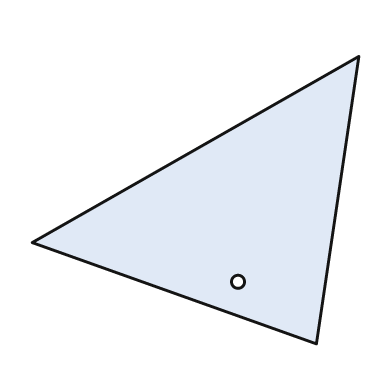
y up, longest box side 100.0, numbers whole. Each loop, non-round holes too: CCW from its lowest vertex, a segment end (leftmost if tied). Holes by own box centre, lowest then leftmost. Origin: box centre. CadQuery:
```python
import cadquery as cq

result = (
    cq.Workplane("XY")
    .moveTo(37.0, -44.0)
    .lineTo(50.0, 44.0)
    .lineTo(-50.0, -13.0)
    .close()
    .moveTo(13.0, -25.0)
    .circle(2.0)
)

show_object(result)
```